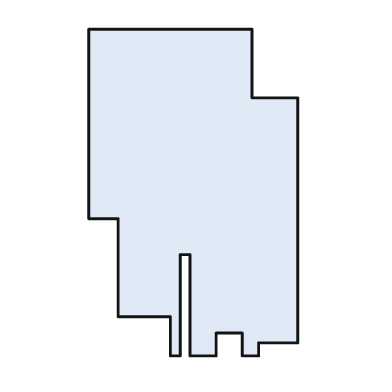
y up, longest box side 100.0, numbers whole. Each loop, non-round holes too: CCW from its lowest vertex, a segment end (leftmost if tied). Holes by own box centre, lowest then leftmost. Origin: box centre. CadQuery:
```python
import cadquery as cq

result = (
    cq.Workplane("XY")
    .moveTo(-7.0, -50.0)
    .lineTo(-4.0, -50.0)
    .lineTo(-4.0, -19.0)
    .lineTo(-1.0, -19.0)
    .lineTo(-1.0, -50.0)
    .lineTo(7.0, -50.0)
    .lineTo(7.0, -43.0)
    .lineTo(15.0, -43.0)
    .lineTo(15.0, -50.0)
    .lineTo(20.0, -50.0)
    .lineTo(20.0, -46.0)
    .lineTo(32.0, -46.0)
    .lineTo(32.0, 29.0)
    .lineTo(18.0, 29.0)
    .lineTo(18.0, 50.0)
    .lineTo(-32.0, 50.0)
    .lineTo(-32.0, -8.0)
    .lineTo(-23.0, -8.0)
    .lineTo(-23.0, -38.0)
    .lineTo(-7.0, -38.0)
    .close()
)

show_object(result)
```